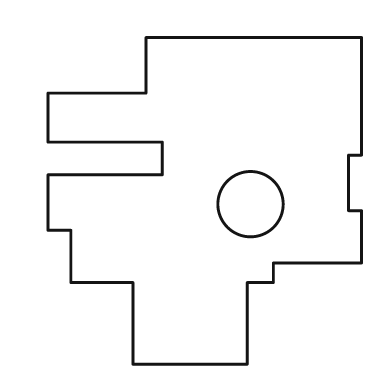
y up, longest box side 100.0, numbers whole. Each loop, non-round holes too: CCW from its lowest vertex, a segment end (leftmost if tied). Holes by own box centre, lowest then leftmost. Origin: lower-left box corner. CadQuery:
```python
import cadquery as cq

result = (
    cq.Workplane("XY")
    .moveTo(26.0, 0.0)
    .lineTo(61.0, 0.0)
    .lineTo(61.0, 25.0)
    .lineTo(69.0, 25.0)
    .lineTo(69.0, 31.0)
    .lineTo(96.0, 31.0)
    .lineTo(96.0, 47.0)
    .lineTo(92.0, 47.0)
    .lineTo(92.0, 64.0)
    .lineTo(96.0, 64.0)
    .lineTo(96.0, 100.0)
    .lineTo(30.0, 100.0)
    .lineTo(30.0, 83.0)
    .lineTo(0.0, 83.0)
    .lineTo(0.0, 68.0)
    .lineTo(35.0, 68.0)
    .lineTo(35.0, 58.0)
    .lineTo(0.0, 58.0)
    .lineTo(0.0, 41.0)
    .lineTo(7.0, 41.0)
    .lineTo(7.0, 25.0)
    .lineTo(26.0, 25.0)
    .close()
    .moveTo(62.0, 49.0)
    .circle(10.0)
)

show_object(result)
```